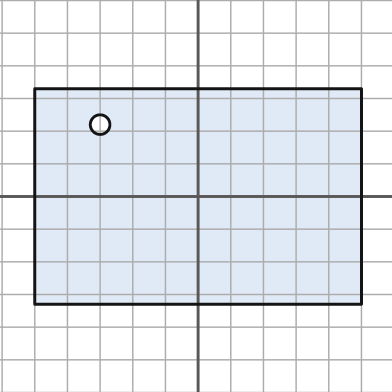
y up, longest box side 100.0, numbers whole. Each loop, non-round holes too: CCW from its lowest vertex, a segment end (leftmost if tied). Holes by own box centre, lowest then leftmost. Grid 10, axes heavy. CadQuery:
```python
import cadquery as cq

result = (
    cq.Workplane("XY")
    .moveTo(-50.0, -33.0)
    .lineTo(50.0, -33.0)
    .lineTo(50.0, 33.0)
    .lineTo(-50.0, 33.0)
    .close()
    .moveTo(-30.0, 22.0)
    .circle(3.0)
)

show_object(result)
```